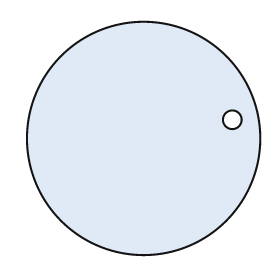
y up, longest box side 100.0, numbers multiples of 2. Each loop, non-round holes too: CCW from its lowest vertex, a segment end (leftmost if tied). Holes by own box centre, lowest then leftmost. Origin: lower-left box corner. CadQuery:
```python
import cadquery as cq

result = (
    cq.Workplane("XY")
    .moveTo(50.0, 50.0)
    .circle(50.0)
    .moveTo(88.0, 58.0)
    .circle(4.0)
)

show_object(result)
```